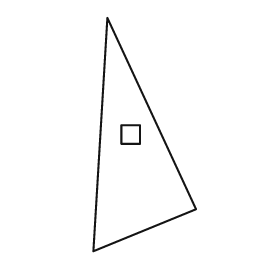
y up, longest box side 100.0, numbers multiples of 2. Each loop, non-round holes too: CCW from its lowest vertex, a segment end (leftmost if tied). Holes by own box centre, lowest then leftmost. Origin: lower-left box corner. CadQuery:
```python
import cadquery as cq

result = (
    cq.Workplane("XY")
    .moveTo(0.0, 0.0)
    .lineTo(44.0, 18.0)
    .lineTo(6.0, 100.0)
    .close()
    .moveTo(12.0, 46.0)
    .lineTo(20.0, 46.0)
    .lineTo(20.0, 54.0)
    .lineTo(12.0, 54.0)
    .close()
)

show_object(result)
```